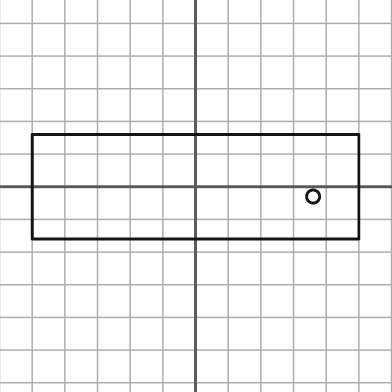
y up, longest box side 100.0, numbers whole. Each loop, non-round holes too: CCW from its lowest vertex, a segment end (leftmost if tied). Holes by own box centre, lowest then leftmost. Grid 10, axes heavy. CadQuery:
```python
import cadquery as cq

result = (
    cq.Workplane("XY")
    .moveTo(-50.0, -16.0)
    .lineTo(50.0, -16.0)
    .lineTo(50.0, 16.0)
    .lineTo(-50.0, 16.0)
    .close()
    .moveTo(36.0, -3.0)
    .circle(2.0)
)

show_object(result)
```